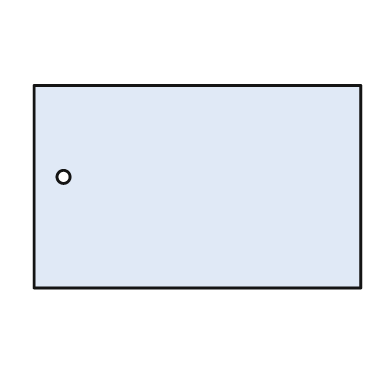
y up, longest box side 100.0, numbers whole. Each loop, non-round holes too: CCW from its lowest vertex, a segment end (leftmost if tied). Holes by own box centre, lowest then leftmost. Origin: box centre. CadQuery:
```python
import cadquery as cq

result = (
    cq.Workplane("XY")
    .moveTo(-50.0, -31.0)
    .lineTo(50.0, -31.0)
    .lineTo(50.0, 31.0)
    .lineTo(-50.0, 31.0)
    .close()
    .moveTo(-41.0, 3.0)
    .circle(2.0)
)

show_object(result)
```